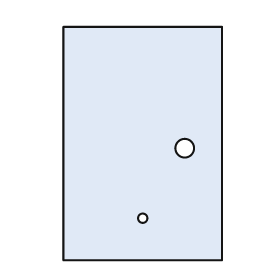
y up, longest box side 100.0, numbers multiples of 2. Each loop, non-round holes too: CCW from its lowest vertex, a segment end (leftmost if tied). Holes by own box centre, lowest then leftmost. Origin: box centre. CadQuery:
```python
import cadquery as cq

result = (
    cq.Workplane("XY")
    .moveTo(-34.0, -50.0)
    .lineTo(34.0, -50.0)
    .lineTo(34.0, 50.0)
    .lineTo(-34.0, 50.0)
    .close()
    .moveTo(0.0, -32.0)
    .circle(2.0)
    .moveTo(18.0, -2.0)
    .circle(4.0)
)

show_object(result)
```